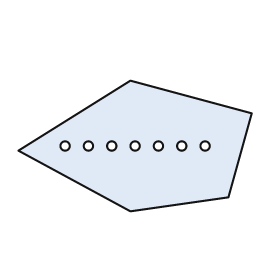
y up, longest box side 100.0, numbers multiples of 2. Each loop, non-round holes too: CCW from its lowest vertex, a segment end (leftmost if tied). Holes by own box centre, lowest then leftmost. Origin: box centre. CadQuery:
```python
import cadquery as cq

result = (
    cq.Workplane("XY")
    .moveTo(-2.0, -28.0)
    .lineTo(40.0, -22.0)
    .lineTo(50.0, 14.0)
    .lineTo(-2.0, 28.0)
    .lineTo(-50.0, -2.0)
    .close()
    .moveTo(-30.0, 0.0)
    .circle(2.0)
    .moveTo(-20.0, 0.0)
    .circle(2.0)
    .moveTo(-10.0, 0.0)
    .circle(2.0)
    .moveTo(0.0, 0.0)
    .circle(2.0)
    .moveTo(10.0, 0.0)
    .circle(2.0)
    .moveTo(20.0, 0.0)
    .circle(2.0)
    .moveTo(30.0, 0.0)
    .circle(2.0)
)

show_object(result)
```